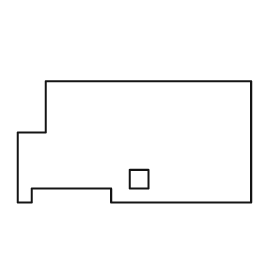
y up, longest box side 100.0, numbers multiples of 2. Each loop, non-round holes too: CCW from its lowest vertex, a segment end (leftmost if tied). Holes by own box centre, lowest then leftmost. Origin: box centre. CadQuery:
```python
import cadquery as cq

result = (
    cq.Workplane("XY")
    .moveTo(-50.0, -26.0)
    .lineTo(-44.0, -26.0)
    .lineTo(-44.0, -20.0)
    .lineTo(-10.0, -20.0)
    .lineTo(-10.0, -26.0)
    .lineTo(50.0, -26.0)
    .lineTo(50.0, 26.0)
    .lineTo(-38.0, 26.0)
    .lineTo(-38.0, 4.0)
    .lineTo(-50.0, 4.0)
    .close()
    .moveTo(-2.0, -20.0)
    .lineTo(6.0, -20.0)
    .lineTo(6.0, -12.0)
    .lineTo(-2.0, -12.0)
    .close()
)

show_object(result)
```